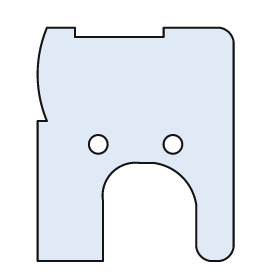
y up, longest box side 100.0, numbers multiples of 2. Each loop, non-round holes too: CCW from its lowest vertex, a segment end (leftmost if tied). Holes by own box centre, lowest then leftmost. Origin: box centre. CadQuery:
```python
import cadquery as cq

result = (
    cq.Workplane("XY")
    .moveTo(-42.0, -50.0)
    .lineTo(-14.0, -50.0)
    .lineTo(-14.0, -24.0)
    .threePointArc((-10.0, -12.0), (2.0, -8.0))
    .lineTo(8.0, -8.0)
    .threePointArc((20.0, -14.0), (26.0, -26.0))
    .lineTo(26.0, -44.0)
    .threePointArc((28.0, -48.0), (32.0, -50.0))
    .lineTo(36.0, -50.0)
    .threePointArc((40.0, -48.0), (42.0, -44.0))
    .lineTo(42.0, 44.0)
    .threePointArc((40.0, 48.0), (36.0, 50.0))
    .lineTo(12.0, 50.0)
    .lineTo(12.0, 46.0)
    .lineTo(-26.0, 46.0)
    .lineTo(-26.0, 50.0)
    .lineTo(-38.0, 50.0)
    .threePointArc((-42.0, 30.0), (-38.0, 10.0))
    .lineTo(-42.0, 10.0)
    .close()
    .moveTo(-16.0, 0.0)
    .circle(4.0)
    .moveTo(16.0, 0.0)
    .circle(4.0)
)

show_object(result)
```